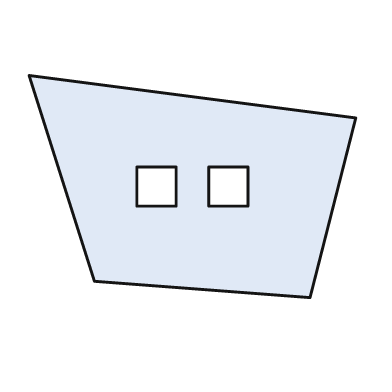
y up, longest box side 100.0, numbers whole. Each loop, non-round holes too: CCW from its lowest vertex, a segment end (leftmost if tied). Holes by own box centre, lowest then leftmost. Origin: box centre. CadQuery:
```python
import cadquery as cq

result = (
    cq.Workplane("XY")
    .moveTo(36.0, -34.0)
    .lineTo(50.0, 21.0)
    .lineTo(-50.0, 34.0)
    .lineTo(-30.0, -29.0)
    .close()
    .moveTo(-17.0, -6.0)
    .lineTo(-5.0, -6.0)
    .lineTo(-5.0, 6.0)
    .lineTo(-17.0, 6.0)
    .close()
    .moveTo(5.0, -6.0)
    .lineTo(17.0, -6.0)
    .lineTo(17.0, 6.0)
    .lineTo(5.0, 6.0)
    .close()
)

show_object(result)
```